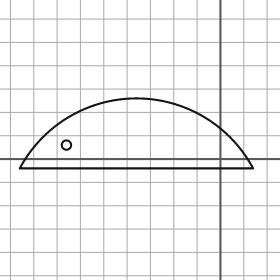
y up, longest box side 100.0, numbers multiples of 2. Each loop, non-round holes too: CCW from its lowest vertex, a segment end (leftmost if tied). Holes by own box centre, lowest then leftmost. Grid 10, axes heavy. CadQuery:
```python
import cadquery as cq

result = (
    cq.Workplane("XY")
    .moveTo(-86.0, -4.0)
    .lineTo(14.0, -4.0)
    .threePointArc((-36.0, 26.0), (-86.0, -4.0))
    .close()
    .moveTo(-66.0, 6.0)
    .circle(2.0)
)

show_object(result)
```